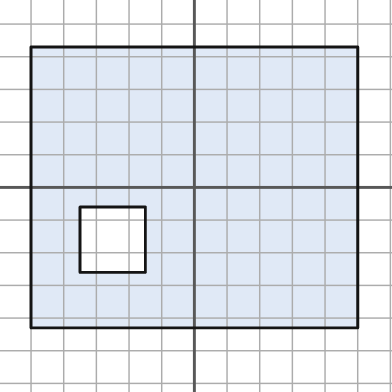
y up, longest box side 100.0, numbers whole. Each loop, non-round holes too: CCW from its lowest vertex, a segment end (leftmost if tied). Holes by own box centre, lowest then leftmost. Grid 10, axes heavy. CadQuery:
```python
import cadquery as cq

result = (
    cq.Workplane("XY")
    .moveTo(-50.0, -43.0)
    .lineTo(50.0, -43.0)
    .lineTo(50.0, 43.0)
    .lineTo(-50.0, 43.0)
    .close()
    .moveTo(-35.0, -26.0)
    .lineTo(-15.0, -26.0)
    .lineTo(-15.0, -6.0)
    .lineTo(-35.0, -6.0)
    .close()
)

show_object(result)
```